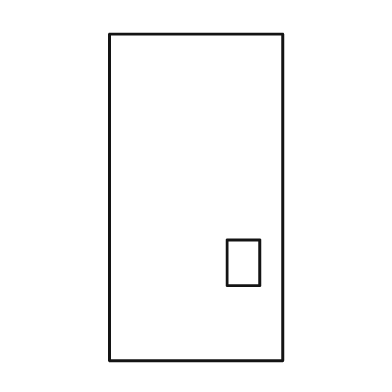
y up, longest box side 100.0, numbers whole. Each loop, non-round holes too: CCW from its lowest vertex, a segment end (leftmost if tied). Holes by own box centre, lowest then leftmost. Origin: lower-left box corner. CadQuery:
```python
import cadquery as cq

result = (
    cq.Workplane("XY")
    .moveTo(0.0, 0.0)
    .lineTo(53.0, 0.0)
    .lineTo(53.0, 100.0)
    .lineTo(0.0, 100.0)
    .close()
    .moveTo(36.0, 23.0)
    .lineTo(46.0, 23.0)
    .lineTo(46.0, 37.0)
    .lineTo(36.0, 37.0)
    .close()
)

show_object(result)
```